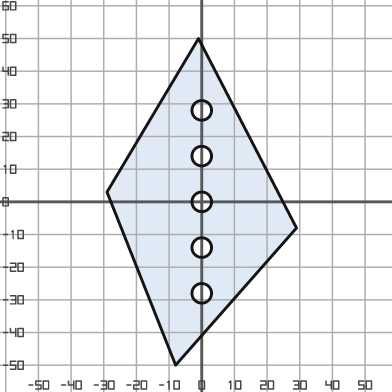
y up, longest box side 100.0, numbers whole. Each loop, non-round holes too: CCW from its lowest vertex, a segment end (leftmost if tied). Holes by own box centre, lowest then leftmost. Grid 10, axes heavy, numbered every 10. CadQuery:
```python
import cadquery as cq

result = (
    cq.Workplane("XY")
    .moveTo(-8.0, -50.0)
    .lineTo(29.0, -8.0)
    .lineTo(-1.0, 50.0)
    .lineTo(-29.0, 3.0)
    .close()
    .moveTo(0.0, -28.0)
    .circle(3.0)
    .moveTo(0.0, -14.0)
    .circle(3.0)
    .moveTo(0.0, 0.0)
    .circle(3.0)
    .moveTo(0.0, 14.0)
    .circle(3.0)
    .moveTo(0.0, 28.0)
    .circle(3.0)
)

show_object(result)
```